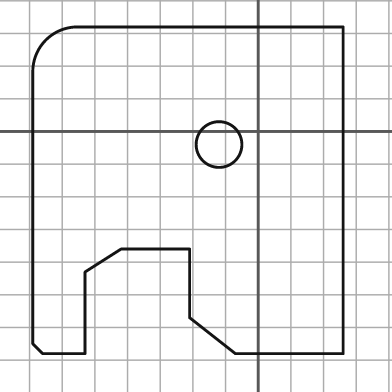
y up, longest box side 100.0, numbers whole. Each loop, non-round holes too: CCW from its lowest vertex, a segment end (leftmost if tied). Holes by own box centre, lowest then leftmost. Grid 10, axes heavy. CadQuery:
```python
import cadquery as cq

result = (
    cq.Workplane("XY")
    .moveTo(-66.0, -68.0)
    .lineTo(-53.0, -68.0)
    .lineTo(-53.0, -43.0)
    .lineTo(-42.0, -36.0)
    .lineTo(-21.0, -36.0)
    .lineTo(-21.0, -57.0)
    .lineTo(-7.0, -68.0)
    .lineTo(26.0, -68.0)
    .lineTo(26.0, 32.0)
    .lineTo(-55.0, 32.0)
    .threePointArc((-65.0, 28.0), (-69.0, 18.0))
    .lineTo(-69.0, -65.0)
    .close()
    .moveTo(-12.0, -4.0)
    .circle(7.0)
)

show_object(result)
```